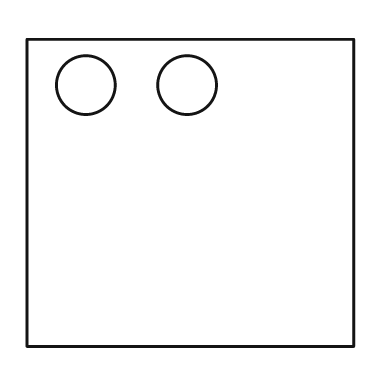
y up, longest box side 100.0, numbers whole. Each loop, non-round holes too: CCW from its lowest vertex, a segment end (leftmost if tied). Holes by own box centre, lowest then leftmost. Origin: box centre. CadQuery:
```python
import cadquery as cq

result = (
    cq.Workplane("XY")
    .moveTo(-50.0, -47.0)
    .lineTo(50.0, -47.0)
    .lineTo(50.0, 47.0)
    .lineTo(-50.0, 47.0)
    .close()
    .moveTo(-32.0, 33.0)
    .circle(9.0)
    .moveTo(-1.0, 33.0)
    .circle(9.0)
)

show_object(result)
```